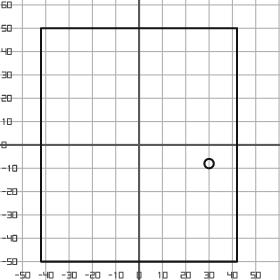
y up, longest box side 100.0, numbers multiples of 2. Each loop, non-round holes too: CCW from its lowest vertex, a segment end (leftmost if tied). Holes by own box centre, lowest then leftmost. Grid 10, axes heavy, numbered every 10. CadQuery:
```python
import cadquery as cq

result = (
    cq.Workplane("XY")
    .moveTo(-42.0, -50.0)
    .lineTo(42.0, -50.0)
    .lineTo(42.0, 50.0)
    .lineTo(-42.0, 50.0)
    .close()
    .moveTo(30.0, -8.0)
    .circle(2.0)
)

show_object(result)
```